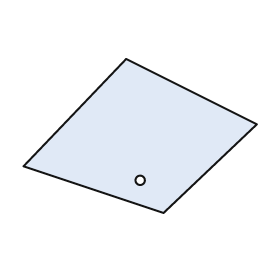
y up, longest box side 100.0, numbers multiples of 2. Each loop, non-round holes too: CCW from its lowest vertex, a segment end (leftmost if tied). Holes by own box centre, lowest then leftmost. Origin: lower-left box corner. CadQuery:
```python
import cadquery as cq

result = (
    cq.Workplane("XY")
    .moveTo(60.0, 0.0)
    .lineTo(100.0, 38.0)
    .lineTo(44.0, 66.0)
    .lineTo(0.0, 20.0)
    .close()
    .moveTo(50.0, 14.0)
    .circle(2.0)
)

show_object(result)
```